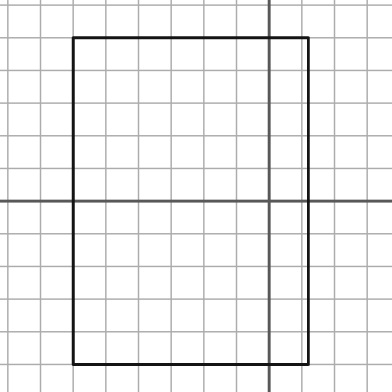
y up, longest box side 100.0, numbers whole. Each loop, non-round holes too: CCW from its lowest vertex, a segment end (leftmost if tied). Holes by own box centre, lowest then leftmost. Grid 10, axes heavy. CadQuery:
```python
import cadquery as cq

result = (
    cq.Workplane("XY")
    .moveTo(-60.0, -50.0)
    .lineTo(12.0, -50.0)
    .lineTo(12.0, 50.0)
    .lineTo(-60.0, 50.0)
    .close()
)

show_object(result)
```